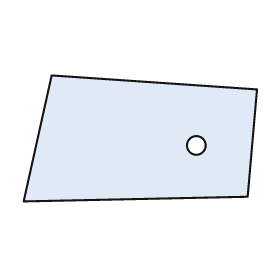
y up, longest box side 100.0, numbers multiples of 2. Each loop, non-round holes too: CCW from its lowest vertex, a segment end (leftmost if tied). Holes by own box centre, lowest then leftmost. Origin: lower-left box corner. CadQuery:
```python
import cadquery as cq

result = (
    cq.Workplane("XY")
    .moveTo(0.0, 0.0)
    .lineTo(96.0, 2.0)
    .lineTo(100.0, 48.0)
    .lineTo(12.0, 54.0)
    .close()
    .moveTo(74.0, 24.0)
    .circle(4.0)
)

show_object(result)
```